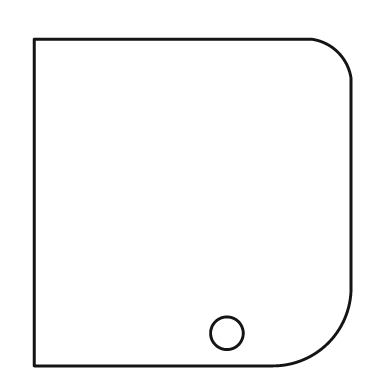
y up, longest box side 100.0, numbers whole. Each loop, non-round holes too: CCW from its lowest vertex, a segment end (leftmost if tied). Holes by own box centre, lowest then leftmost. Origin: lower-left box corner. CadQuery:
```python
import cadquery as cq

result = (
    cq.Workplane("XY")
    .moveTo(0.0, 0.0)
    .lineTo(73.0, 0.0)
    .threePointArc((90.0, 7.0), (97.0, 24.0))
    .lineTo(97.0, 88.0)
    .threePointArc((93.0, 96.0), (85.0, 100.0))
    .lineTo(0.0, 100.0)
    .close()
    .moveTo(59.0, 10.0)
    .circle(5.0)
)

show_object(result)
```